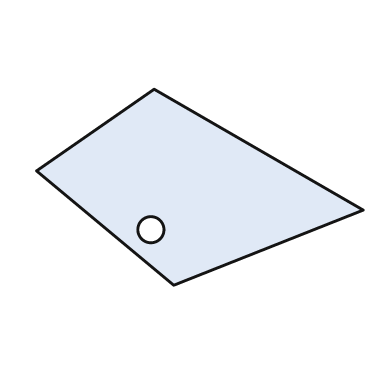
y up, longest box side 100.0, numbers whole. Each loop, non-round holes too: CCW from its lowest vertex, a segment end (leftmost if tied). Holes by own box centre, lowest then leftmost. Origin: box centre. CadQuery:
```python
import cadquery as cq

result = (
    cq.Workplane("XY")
    .moveTo(-8.0, -30.0)
    .lineTo(50.0, -7.0)
    .lineTo(-14.0, 30.0)
    .lineTo(-50.0, 5.0)
    .close()
    .moveTo(-15.0, -13.0)
    .circle(4.0)
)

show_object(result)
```